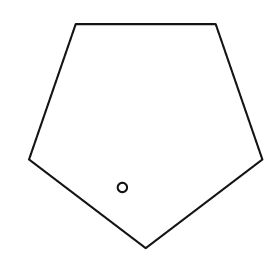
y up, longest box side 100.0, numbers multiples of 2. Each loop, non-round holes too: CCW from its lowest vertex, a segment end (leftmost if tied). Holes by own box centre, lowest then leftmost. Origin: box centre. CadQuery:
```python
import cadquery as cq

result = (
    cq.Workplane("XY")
    .moveTo(0.0, -48.0)
    .lineTo(50.0, -10.0)
    .lineTo(30.0, 48.0)
    .lineTo(-30.0, 48.0)
    .lineTo(-50.0, -10.0)
    .close()
    .moveTo(-10.0, -22.0)
    .circle(2.0)
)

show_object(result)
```